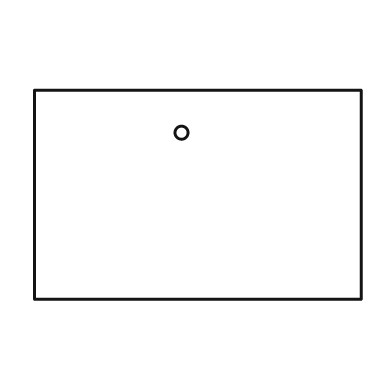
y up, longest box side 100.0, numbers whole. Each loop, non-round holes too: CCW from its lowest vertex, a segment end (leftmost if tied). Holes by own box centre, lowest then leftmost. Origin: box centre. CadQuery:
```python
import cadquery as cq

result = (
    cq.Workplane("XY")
    .moveTo(-50.0, -32.0)
    .lineTo(50.0, -32.0)
    .lineTo(50.0, 32.0)
    .lineTo(-50.0, 32.0)
    .close()
    .moveTo(-5.0, 19.0)
    .circle(2.0)
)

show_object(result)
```